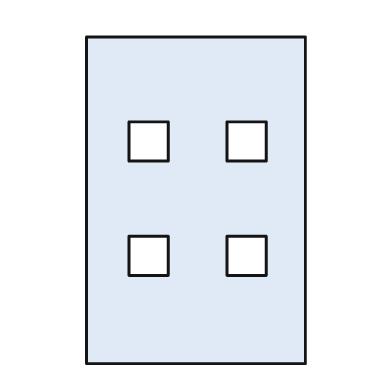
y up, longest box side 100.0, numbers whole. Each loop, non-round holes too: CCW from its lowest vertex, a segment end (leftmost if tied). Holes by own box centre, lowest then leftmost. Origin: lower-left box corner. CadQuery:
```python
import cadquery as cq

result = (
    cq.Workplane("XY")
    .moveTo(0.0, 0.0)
    .lineTo(67.0, 0.0)
    .lineTo(67.0, 100.0)
    .lineTo(0.0, 100.0)
    .close()
    .moveTo(13.0, 27.0)
    .lineTo(25.0, 27.0)
    .lineTo(25.0, 39.0)
    .lineTo(13.0, 39.0)
    .close()
    .moveTo(43.0, 27.0)
    .lineTo(55.0, 27.0)
    .lineTo(55.0, 39.0)
    .lineTo(43.0, 39.0)
    .close()
    .moveTo(13.0, 62.0)
    .lineTo(25.0, 62.0)
    .lineTo(25.0, 74.0)
    .lineTo(13.0, 74.0)
    .close()
    .moveTo(43.0, 62.0)
    .lineTo(55.0, 62.0)
    .lineTo(55.0, 74.0)
    .lineTo(43.0, 74.0)
    .close()
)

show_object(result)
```